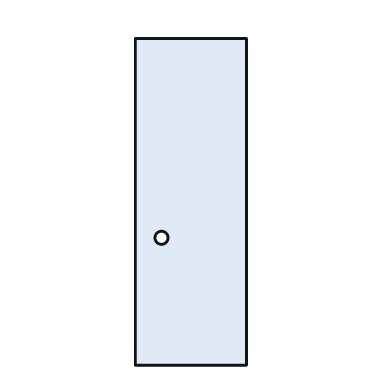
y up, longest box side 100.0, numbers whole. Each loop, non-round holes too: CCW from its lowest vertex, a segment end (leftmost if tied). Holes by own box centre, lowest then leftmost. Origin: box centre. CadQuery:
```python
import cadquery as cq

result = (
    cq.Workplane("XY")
    .moveTo(-17.0, -50.0)
    .lineTo(17.0, -50.0)
    .lineTo(17.0, 50.0)
    .lineTo(-17.0, 50.0)
    .close()
    .moveTo(-9.0, -11.0)
    .circle(2.0)
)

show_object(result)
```